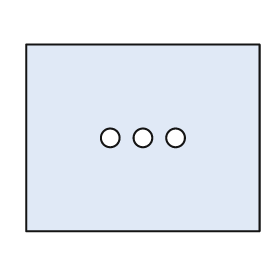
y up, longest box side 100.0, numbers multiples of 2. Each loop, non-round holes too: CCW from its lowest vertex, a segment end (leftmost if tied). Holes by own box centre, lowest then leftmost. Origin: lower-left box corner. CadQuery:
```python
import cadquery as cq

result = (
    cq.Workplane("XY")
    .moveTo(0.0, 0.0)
    .lineTo(100.0, 0.0)
    .lineTo(100.0, 80.0)
    .lineTo(0.0, 80.0)
    .close()
    .moveTo(36.0, 40.0)
    .circle(4.0)
    .moveTo(50.0, 40.0)
    .circle(4.0)
    .moveTo(64.0, 40.0)
    .circle(4.0)
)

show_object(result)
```